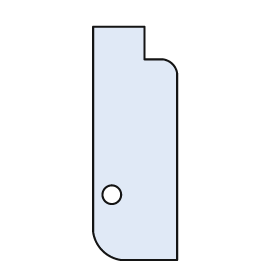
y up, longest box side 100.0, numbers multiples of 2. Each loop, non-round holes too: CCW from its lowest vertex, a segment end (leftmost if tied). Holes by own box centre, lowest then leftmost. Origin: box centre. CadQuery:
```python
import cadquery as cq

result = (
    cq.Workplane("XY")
    .moveTo(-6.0, -50.0)
    .lineTo(18.0, -50.0)
    .lineTo(18.0, 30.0)
    .threePointArc((16.0, 34.0), (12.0, 36.0))
    .lineTo(4.0, 36.0)
    .lineTo(4.0, 50.0)
    .lineTo(-18.0, 50.0)
    .lineTo(-18.0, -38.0)
    .threePointArc((-14.0, -46.0), (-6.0, -50.0))
    .close()
    .moveTo(-10.0, -22.0)
    .circle(4.0)
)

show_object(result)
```